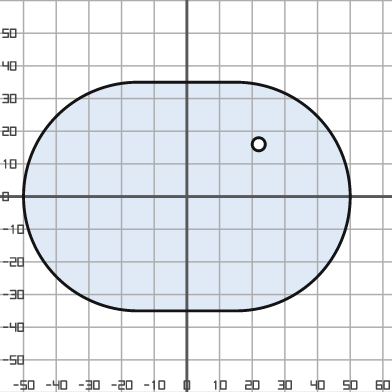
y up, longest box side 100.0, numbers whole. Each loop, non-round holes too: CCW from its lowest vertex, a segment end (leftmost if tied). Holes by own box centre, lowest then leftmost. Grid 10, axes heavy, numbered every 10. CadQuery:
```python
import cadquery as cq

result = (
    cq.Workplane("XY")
    .moveTo(-15.0, -35.0)
    .lineTo(15.0, -35.0)
    .threePointArc((50.0, 0.0), (15.0, 35.0))
    .lineTo(-15.0, 35.0)
    .threePointArc((-50.0, 0.0), (-15.0, -35.0))
    .close()
    .moveTo(22.0, 16.0)
    .circle(2.0)
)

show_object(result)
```